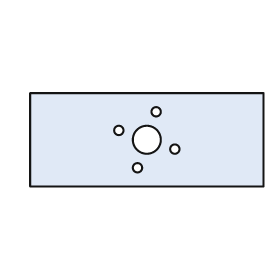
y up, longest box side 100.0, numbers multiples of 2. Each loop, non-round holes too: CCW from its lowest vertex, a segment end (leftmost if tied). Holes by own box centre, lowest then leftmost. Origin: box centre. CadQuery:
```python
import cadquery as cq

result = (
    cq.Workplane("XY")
    .moveTo(-50.0, -20.0)
    .lineTo(50.0, -20.0)
    .lineTo(50.0, 20.0)
    .lineTo(-50.0, 20.0)
    .close()
    .moveTo(-4.0, -12.0)
    .circle(2.0)
    .moveTo(12.0, -4.0)
    .circle(2.0)
    .moveTo(0.0, 0.0)
    .circle(6.0)
    .moveTo(-12.0, 4.0)
    .circle(2.0)
    .moveTo(4.0, 12.0)
    .circle(2.0)
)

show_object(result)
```